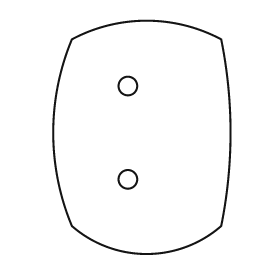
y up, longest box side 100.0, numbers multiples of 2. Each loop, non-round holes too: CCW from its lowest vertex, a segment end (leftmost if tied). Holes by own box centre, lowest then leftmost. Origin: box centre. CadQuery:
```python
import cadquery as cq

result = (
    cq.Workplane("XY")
    .moveTo(-30.0, -38.0)
    .threePointArc((2.0, -50.0), (34.0, -38.0))
    .threePointArc((38.0, 2.0), (34.0, 42.0))
    .threePointArc((2.0, 50.0), (-30.0, 42.0))
    .threePointArc((-38.0, 2.0), (-30.0, -38.0))
    .close()
    .moveTo(-6.0, -18.0)
    .circle(4.0)
    .moveTo(-6.0, 22.0)
    .circle(4.0)
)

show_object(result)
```